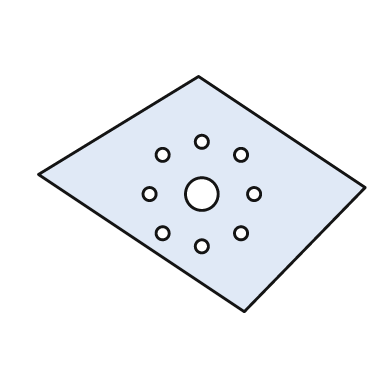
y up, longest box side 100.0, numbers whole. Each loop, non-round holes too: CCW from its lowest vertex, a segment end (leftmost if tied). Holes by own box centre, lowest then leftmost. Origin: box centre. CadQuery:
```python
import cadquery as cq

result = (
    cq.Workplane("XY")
    .moveTo(13.0, -36.0)
    .lineTo(50.0, 2.0)
    .lineTo(-1.0, 36.0)
    .lineTo(-50.0, 6.0)
    .close()
    .moveTo(0.0, -16.0)
    .circle(2.0)
    .moveTo(-12.0, -12.0)
    .circle(2.0)
    .moveTo(12.0, -12.0)
    .circle(2.0)
    .moveTo(-16.0, 0.0)
    .circle(2.0)
    .moveTo(0.0, 0.0)
    .circle(5.0)
    .moveTo(16.0, 0.0)
    .circle(2.0)
    .moveTo(-12.0, 12.0)
    .circle(2.0)
    .moveTo(12.0, 12.0)
    .circle(2.0)
    .moveTo(0.0, 16.0)
    .circle(2.0)
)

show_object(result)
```